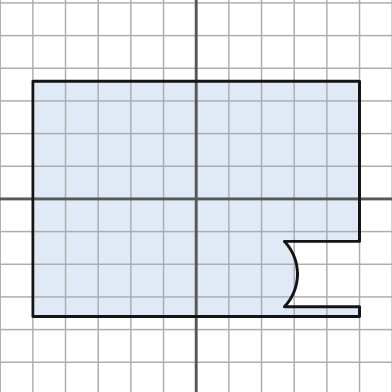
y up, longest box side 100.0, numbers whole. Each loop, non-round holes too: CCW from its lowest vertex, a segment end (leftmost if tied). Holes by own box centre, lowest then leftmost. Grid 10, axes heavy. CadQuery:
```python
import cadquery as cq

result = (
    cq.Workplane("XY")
    .moveTo(-50.0, -36.0)
    .lineTo(50.0, -36.0)
    .lineTo(50.0, -33.0)
    .lineTo(27.0, -33.0)
    .threePointArc((31.0, -23.0), (27.0, -13.0))
    .lineTo(50.0, -13.0)
    .lineTo(50.0, 36.0)
    .lineTo(-50.0, 36.0)
    .close()
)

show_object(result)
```